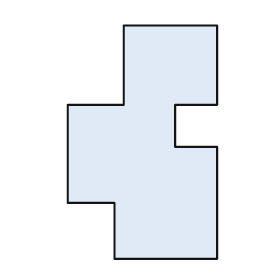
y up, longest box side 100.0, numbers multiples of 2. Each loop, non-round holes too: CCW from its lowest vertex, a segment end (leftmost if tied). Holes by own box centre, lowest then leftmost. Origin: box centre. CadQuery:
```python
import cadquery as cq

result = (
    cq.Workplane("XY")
    .moveTo(-12.0, -50.0)
    .lineTo(32.0, -50.0)
    .lineTo(32.0, -2.0)
    .lineTo(14.0, -2.0)
    .lineTo(14.0, 16.0)
    .lineTo(32.0, 16.0)
    .lineTo(32.0, 50.0)
    .lineTo(-8.0, 50.0)
    .lineTo(-8.0, 16.0)
    .lineTo(-32.0, 16.0)
    .lineTo(-32.0, -26.0)
    .lineTo(-12.0, -26.0)
    .close()
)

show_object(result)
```